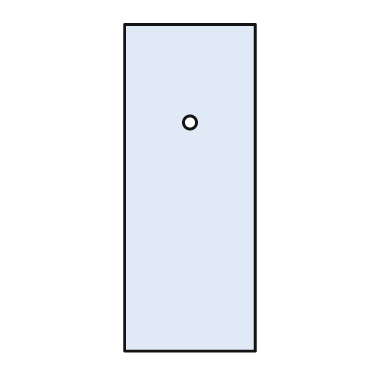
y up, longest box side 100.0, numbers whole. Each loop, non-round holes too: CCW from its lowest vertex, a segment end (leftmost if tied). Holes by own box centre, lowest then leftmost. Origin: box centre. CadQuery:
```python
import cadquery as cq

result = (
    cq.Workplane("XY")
    .moveTo(-20.0, -50.0)
    .lineTo(20.0, -50.0)
    .lineTo(20.0, 50.0)
    .lineTo(-20.0, 50.0)
    .close()
    .moveTo(0.0, 20.0)
    .circle(2.0)
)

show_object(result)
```